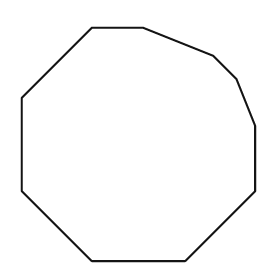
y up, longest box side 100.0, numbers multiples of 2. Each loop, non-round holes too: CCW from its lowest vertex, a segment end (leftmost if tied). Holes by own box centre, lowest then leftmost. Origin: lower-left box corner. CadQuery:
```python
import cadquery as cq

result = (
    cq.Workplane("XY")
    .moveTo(30.0, 0.0)
    .lineTo(70.0, 0.0)
    .lineTo(100.0, 30.0)
    .lineTo(100.0, 58.0)
    .lineTo(92.0, 78.0)
    .lineTo(82.0, 88.0)
    .lineTo(52.0, 100.0)
    .lineTo(30.0, 100.0)
    .lineTo(0.0, 70.0)
    .lineTo(0.0, 30.0)
    .close()
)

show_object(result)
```